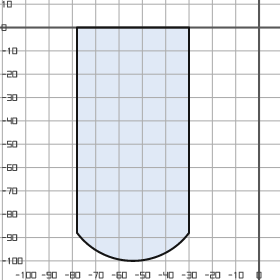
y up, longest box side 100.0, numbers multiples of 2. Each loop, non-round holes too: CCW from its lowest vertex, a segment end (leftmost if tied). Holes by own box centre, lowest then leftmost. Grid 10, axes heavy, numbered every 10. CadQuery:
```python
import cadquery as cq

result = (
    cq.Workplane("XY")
    .moveTo(-78.0, -88.0)
    .threePointArc((-54.0, -100.0), (-30.0, -88.0))
    .lineTo(-30.0, 0.0)
    .lineTo(-78.0, 0.0)
    .close()
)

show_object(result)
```